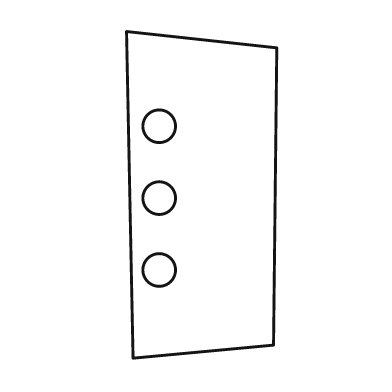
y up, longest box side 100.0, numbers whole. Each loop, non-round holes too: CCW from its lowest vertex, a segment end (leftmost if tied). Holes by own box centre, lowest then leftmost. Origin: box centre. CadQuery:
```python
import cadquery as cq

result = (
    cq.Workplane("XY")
    .moveTo(-21.0, -50.0)
    .lineTo(22.0, -46.0)
    .lineTo(23.0, 45.0)
    .lineTo(-23.0, 50.0)
    .close()
    .moveTo(-13.0, -23.0)
    .circle(5.0)
    .moveTo(-13.0, -1.0)
    .circle(5.0)
    .moveTo(-13.0, 21.0)
    .circle(5.0)
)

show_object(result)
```